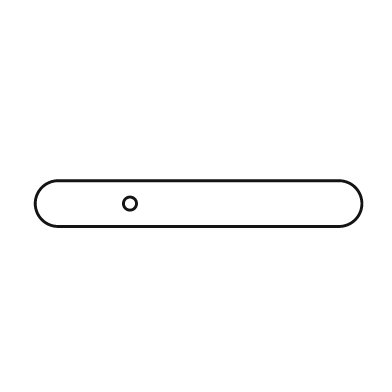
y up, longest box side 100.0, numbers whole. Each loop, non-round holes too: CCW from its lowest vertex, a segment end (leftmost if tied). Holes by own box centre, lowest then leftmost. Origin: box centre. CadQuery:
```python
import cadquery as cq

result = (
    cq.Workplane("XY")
    .moveTo(-43.0, -7.0)
    .lineTo(43.0, -7.0)
    .threePointArc((50.0, 0.0), (43.0, 7.0))
    .lineTo(-43.0, 7.0)
    .threePointArc((-50.0, 0.0), (-43.0, -7.0))
    .close()
    .moveTo(-21.0, 0.0)
    .circle(2.0)
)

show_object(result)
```